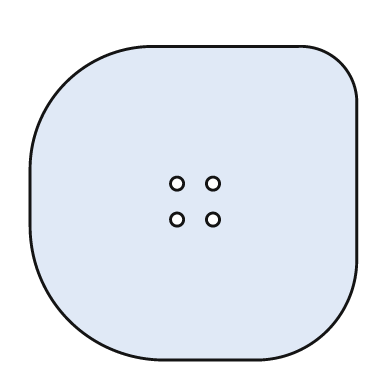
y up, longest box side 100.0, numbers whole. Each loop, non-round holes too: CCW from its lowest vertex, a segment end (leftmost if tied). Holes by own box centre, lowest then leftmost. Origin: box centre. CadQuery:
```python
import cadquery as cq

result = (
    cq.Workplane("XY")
    .moveTo(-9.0, -48.0)
    .lineTo(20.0, -48.0)
    .threePointArc((41.0, -39.0), (50.0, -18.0))
    .lineTo(50.0, 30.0)
    .threePointArc((45.0, 43.0), (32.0, 48.0))
    .lineTo(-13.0, 48.0)
    .threePointArc((-39.0, 37.0), (-50.0, 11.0))
    .lineTo(-50.0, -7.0)
    .threePointArc((-38.0, -36.0), (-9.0, -48.0))
    .close()
    .moveTo(-5.0, -5.0)
    .circle(2.0)
    .moveTo(6.0, -5.0)
    .circle(2.0)
    .moveTo(-5.0, 6.0)
    .circle(2.0)
    .moveTo(6.0, 6.0)
    .circle(2.0)
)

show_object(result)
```